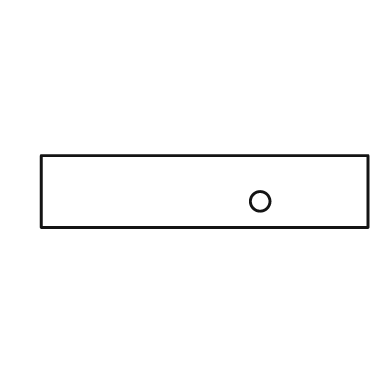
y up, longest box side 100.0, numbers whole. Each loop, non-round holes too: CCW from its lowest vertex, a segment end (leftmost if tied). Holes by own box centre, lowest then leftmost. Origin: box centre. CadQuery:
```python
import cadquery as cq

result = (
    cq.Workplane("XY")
    .moveTo(-50.0, -11.0)
    .lineTo(50.0, -11.0)
    .lineTo(50.0, 11.0)
    .lineTo(-50.0, 11.0)
    .close()
    .moveTo(17.0, -3.0)
    .circle(3.0)
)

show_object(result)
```